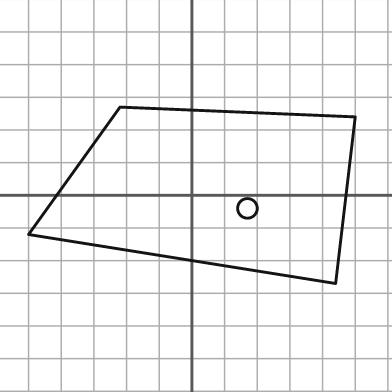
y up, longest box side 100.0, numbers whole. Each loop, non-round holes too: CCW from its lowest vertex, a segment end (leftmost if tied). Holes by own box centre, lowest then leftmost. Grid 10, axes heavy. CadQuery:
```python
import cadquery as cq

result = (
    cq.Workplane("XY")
    .moveTo(44.0, -27.0)
    .lineTo(50.0, 24.0)
    .lineTo(-22.0, 27.0)
    .lineTo(-50.0, -12.0)
    .close()
    .moveTo(17.0, -4.0)
    .circle(3.0)
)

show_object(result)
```